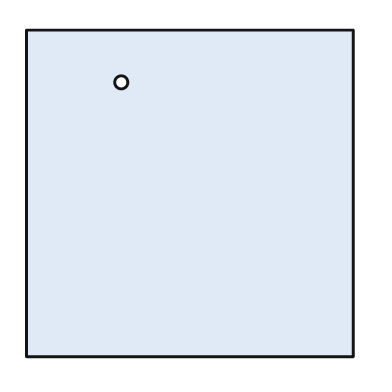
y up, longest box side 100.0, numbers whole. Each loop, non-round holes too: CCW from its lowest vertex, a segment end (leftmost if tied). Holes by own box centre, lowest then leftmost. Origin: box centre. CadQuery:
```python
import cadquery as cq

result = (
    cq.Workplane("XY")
    .moveTo(-50.0, -50.0)
    .lineTo(50.0, -50.0)
    .lineTo(50.0, 50.0)
    .lineTo(-50.0, 50.0)
    .close()
    .moveTo(-21.0, 34.0)
    .circle(2.0)
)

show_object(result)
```